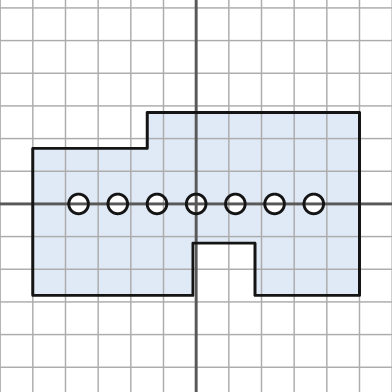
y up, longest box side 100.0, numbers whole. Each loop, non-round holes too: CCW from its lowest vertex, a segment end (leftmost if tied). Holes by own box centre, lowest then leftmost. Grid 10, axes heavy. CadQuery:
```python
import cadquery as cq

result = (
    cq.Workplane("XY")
    .moveTo(-50.0, -28.0)
    .lineTo(-1.0, -28.0)
    .lineTo(-1.0, -12.0)
    .lineTo(18.0, -12.0)
    .lineTo(18.0, -28.0)
    .lineTo(50.0, -28.0)
    .lineTo(50.0, 28.0)
    .lineTo(-15.0, 28.0)
    .lineTo(-15.0, 17.0)
    .lineTo(-50.0, 17.0)
    .close()
    .moveTo(-36.0, 0.0)
    .circle(3.0)
    .moveTo(-24.0, 0.0)
    .circle(3.0)
    .moveTo(-12.0, 0.0)
    .circle(3.0)
    .moveTo(0.0, 0.0)
    .circle(3.0)
    .moveTo(12.0, 0.0)
    .circle(3.0)
    .moveTo(24.0, 0.0)
    .circle(3.0)
    .moveTo(36.0, 0.0)
    .circle(3.0)
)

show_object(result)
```